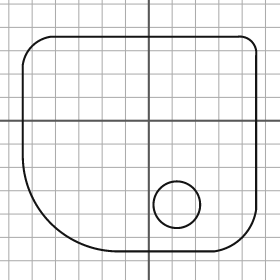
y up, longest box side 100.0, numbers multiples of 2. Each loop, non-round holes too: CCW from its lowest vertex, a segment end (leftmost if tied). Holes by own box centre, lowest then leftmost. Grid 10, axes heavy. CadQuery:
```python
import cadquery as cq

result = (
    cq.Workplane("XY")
    .moveTo(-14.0, -56.0)
    .lineTo(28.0, -56.0)
    .threePointArc((40.0, -50.0), (46.0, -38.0))
    .lineTo(46.0, 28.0)
    .threePointArc((44.0, 34.0), (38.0, 36.0))
    .lineTo(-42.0, 36.0)
    .threePointArc((-50.0, 32.0), (-54.0, 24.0))
    .lineTo(-54.0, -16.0)
    .threePointArc((-42.0, -44.0), (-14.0, -56.0))
    .close()
    .moveTo(12.0, -36.0)
    .circle(10.0)
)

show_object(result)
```